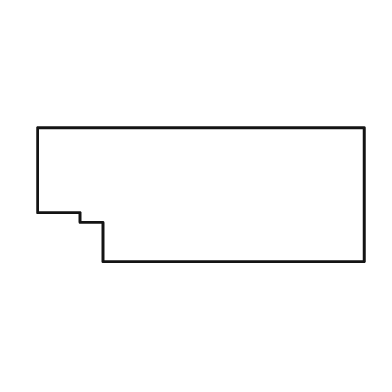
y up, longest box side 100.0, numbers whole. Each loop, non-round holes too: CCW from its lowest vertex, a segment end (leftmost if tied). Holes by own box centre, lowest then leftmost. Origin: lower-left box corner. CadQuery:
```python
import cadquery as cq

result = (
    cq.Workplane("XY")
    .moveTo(20.0, 0.0)
    .lineTo(100.0, 0.0)
    .lineTo(100.0, 41.0)
    .lineTo(0.0, 41.0)
    .lineTo(0.0, 15.0)
    .lineTo(13.0, 15.0)
    .lineTo(13.0, 12.0)
    .lineTo(20.0, 12.0)
    .close()
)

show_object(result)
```